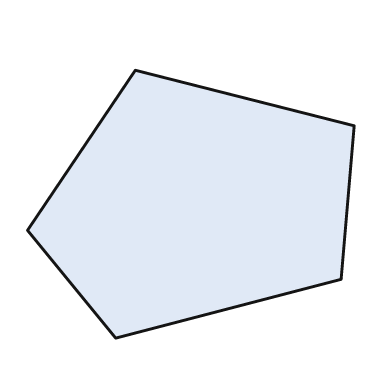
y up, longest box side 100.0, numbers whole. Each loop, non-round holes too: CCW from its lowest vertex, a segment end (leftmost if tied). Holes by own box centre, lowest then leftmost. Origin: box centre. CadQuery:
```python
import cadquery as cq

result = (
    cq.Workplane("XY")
    .moveTo(-23.0, -41.0)
    .lineTo(46.0, -23.0)
    .lineTo(50.0, 24.0)
    .lineTo(-17.0, 41.0)
    .lineTo(-50.0, -8.0)
    .close()
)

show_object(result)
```